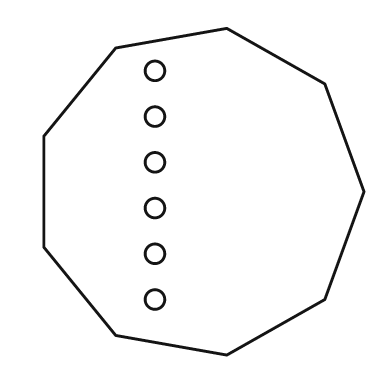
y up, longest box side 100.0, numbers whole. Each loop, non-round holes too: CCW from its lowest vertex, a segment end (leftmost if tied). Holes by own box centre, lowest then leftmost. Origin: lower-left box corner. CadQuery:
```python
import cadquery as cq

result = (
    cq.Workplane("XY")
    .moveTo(56.0, 0.0)
    .lineTo(86.0, 17.0)
    .lineTo(98.0, 50.0)
    .lineTo(86.0, 83.0)
    .lineTo(56.0, 100.0)
    .lineTo(22.0, 94.0)
    .lineTo(0.0, 67.0)
    .lineTo(0.0, 33.0)
    .lineTo(22.0, 6.0)
    .close()
    .moveTo(34.0, 17.0)
    .circle(3.0)
    .moveTo(34.0, 31.0)
    .circle(3.0)
    .moveTo(34.0, 45.0)
    .circle(3.0)
    .moveTo(34.0, 59.0)
    .circle(3.0)
    .moveTo(34.0, 73.0)
    .circle(3.0)
    .moveTo(34.0, 87.0)
    .circle(3.0)
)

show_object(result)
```